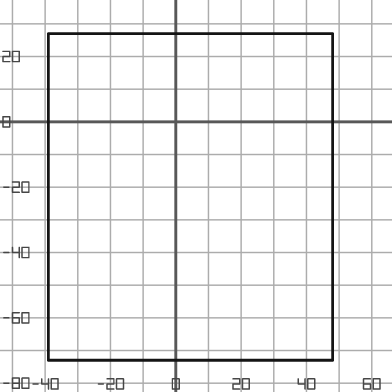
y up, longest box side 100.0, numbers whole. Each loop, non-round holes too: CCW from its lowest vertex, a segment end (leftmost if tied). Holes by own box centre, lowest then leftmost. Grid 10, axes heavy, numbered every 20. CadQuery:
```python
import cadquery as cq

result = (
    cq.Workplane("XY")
    .moveTo(-39.0, -73.0)
    .lineTo(48.0, -73.0)
    .lineTo(48.0, 27.0)
    .lineTo(-39.0, 27.0)
    .close()
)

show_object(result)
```